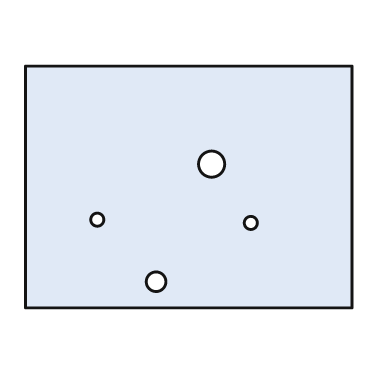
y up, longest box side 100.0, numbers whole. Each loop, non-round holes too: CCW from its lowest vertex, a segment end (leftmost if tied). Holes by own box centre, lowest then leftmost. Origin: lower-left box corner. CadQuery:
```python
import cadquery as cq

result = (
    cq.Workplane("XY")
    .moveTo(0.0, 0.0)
    .lineTo(100.0, 0.0)
    .lineTo(100.0, 74.0)
    .lineTo(0.0, 74.0)
    .close()
    .moveTo(40.0, 8.0)
    .circle(3.0)
    .moveTo(69.0, 26.0)
    .circle(2.0)
    .moveTo(22.0, 27.0)
    .circle(2.0)
    .moveTo(57.0, 44.0)
    .circle(4.0)
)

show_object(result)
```